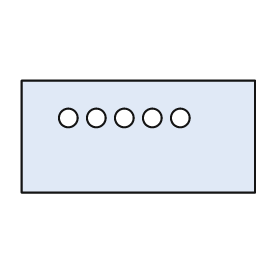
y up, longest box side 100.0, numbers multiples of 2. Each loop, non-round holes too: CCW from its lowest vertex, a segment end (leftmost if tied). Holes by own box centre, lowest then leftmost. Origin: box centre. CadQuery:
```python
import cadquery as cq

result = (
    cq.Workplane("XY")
    .moveTo(-50.0, -24.0)
    .lineTo(50.0, -24.0)
    .lineTo(50.0, 24.0)
    .lineTo(-50.0, 24.0)
    .close()
    .moveTo(-30.0, 8.0)
    .circle(4.0)
    .moveTo(-18.0, 8.0)
    .circle(4.0)
    .moveTo(-6.0, 8.0)
    .circle(4.0)
    .moveTo(6.0, 8.0)
    .circle(4.0)
    .moveTo(18.0, 8.0)
    .circle(4.0)
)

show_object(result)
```